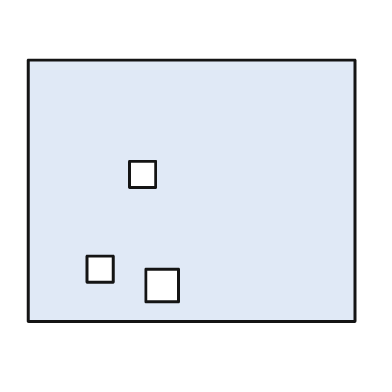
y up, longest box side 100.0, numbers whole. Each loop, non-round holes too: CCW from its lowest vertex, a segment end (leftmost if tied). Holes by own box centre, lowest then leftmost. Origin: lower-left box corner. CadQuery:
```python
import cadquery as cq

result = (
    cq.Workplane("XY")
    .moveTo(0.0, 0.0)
    .lineTo(100.0, 0.0)
    .lineTo(100.0, 80.0)
    .lineTo(0.0, 80.0)
    .close()
    .moveTo(36.0, 6.0)
    .lineTo(46.0, 6.0)
    .lineTo(46.0, 16.0)
    .lineTo(36.0, 16.0)
    .close()
    .moveTo(18.0, 12.0)
    .lineTo(26.0, 12.0)
    .lineTo(26.0, 20.0)
    .lineTo(18.0, 20.0)
    .close()
    .moveTo(31.0, 41.0)
    .lineTo(39.0, 41.0)
    .lineTo(39.0, 49.0)
    .lineTo(31.0, 49.0)
    .close()
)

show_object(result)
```